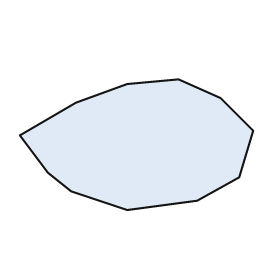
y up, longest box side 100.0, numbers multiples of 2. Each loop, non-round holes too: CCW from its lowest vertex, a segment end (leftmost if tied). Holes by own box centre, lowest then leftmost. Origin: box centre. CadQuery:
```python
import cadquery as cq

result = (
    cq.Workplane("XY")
    .moveTo(-4.0, -28.0)
    .lineTo(26.0, -24.0)
    .lineTo(44.0, -14.0)
    .lineTo(50.0, 6.0)
    .lineTo(36.0, 20.0)
    .lineTo(18.0, 28.0)
    .lineTo(-4.0, 26.0)
    .lineTo(-26.0, 18.0)
    .lineTo(-50.0, 4.0)
    .lineTo(-38.0, -12.0)
    .lineTo(-28.0, -20.0)
    .close()
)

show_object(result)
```